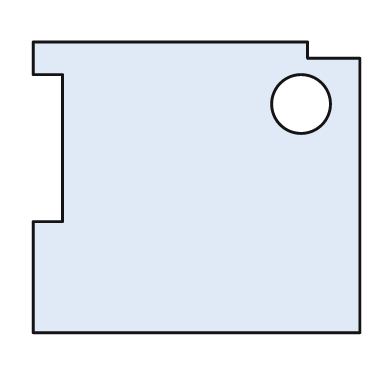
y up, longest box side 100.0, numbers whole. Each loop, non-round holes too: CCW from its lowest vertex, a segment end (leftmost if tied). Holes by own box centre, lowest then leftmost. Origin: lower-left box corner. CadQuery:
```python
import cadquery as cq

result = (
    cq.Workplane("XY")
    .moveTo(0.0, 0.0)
    .lineTo(100.0, 0.0)
    .lineTo(100.0, 84.0)
    .lineTo(84.0, 84.0)
    .lineTo(84.0, 89.0)
    .lineTo(0.0, 89.0)
    .lineTo(0.0, 79.0)
    .lineTo(9.0, 79.0)
    .lineTo(9.0, 34.0)
    .lineTo(0.0, 34.0)
    .close()
    .moveTo(82.0, 70.0)
    .circle(9.0)
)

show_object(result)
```